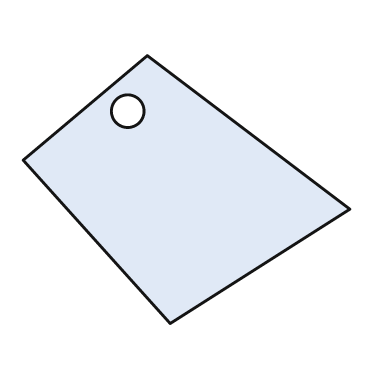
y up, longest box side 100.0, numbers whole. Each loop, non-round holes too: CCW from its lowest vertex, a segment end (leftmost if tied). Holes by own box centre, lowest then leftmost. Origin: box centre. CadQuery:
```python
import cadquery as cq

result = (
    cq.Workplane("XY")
    .moveTo(-5.0, -41.0)
    .lineTo(50.0, -6.0)
    .lineTo(-12.0, 41.0)
    .lineTo(-50.0, 9.0)
    .close()
    .moveTo(-18.0, 24.0)
    .circle(5.0)
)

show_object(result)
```